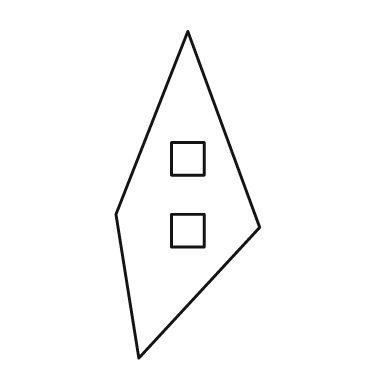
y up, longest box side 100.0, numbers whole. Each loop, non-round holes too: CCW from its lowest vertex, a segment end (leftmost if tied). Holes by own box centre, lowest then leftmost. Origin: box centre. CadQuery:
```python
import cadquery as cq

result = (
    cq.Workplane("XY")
    .moveTo(-15.0, -50.0)
    .lineTo(22.0, -10.0)
    .lineTo(0.0, 50.0)
    .lineTo(-22.0, -6.0)
    .close()
    .moveTo(-5.0, -16.0)
    .lineTo(5.0, -16.0)
    .lineTo(5.0, -6.0)
    .lineTo(-5.0, -6.0)
    .close()
    .moveTo(-5.0, 6.0)
    .lineTo(5.0, 6.0)
    .lineTo(5.0, 16.0)
    .lineTo(-5.0, 16.0)
    .close()
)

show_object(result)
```